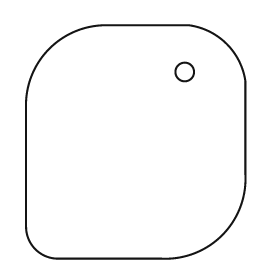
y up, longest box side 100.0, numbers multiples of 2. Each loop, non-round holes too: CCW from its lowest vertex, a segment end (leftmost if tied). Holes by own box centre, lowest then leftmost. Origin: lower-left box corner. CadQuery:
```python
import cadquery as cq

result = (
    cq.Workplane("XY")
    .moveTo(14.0, 0.0)
    .lineTo(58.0, 0.0)
    .threePointArc((84.0, 10.0), (94.0, 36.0))
    .lineTo(94.0, 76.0)
    .threePointArc((86.0, 92.0), (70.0, 100.0))
    .lineTo(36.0, 100.0)
    .threePointArc((10.0, 90.0), (0.0, 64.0))
    .lineTo(0.0, 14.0)
    .threePointArc((4.0, 4.0), (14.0, 0.0))
    .close()
    .moveTo(68.0, 80.0)
    .circle(4.0)
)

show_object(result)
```